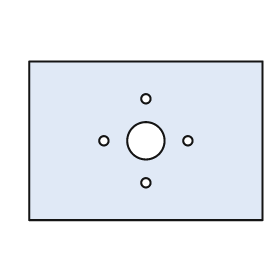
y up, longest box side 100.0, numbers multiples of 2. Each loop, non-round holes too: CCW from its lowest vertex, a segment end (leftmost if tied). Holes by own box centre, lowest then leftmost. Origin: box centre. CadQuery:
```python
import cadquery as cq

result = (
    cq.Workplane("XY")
    .moveTo(-50.0, -34.0)
    .lineTo(50.0, -34.0)
    .lineTo(50.0, 34.0)
    .lineTo(-50.0, 34.0)
    .close()
    .moveTo(0.0, -18.0)
    .circle(2.0)
    .moveTo(-18.0, 0.0)
    .circle(2.0)
    .moveTo(0.0, 0.0)
    .circle(8.0)
    .moveTo(18.0, 0.0)
    .circle(2.0)
    .moveTo(0.0, 18.0)
    .circle(2.0)
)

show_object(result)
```